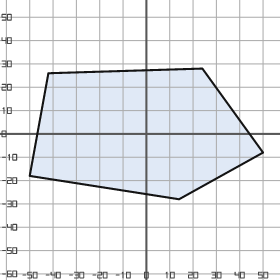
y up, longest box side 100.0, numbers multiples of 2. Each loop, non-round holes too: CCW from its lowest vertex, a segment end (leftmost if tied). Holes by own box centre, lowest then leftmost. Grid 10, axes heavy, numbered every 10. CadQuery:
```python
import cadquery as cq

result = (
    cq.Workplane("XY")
    .moveTo(14.0, -28.0)
    .lineTo(50.0, -8.0)
    .lineTo(24.0, 28.0)
    .lineTo(-42.0, 26.0)
    .lineTo(-50.0, -18.0)
    .close()
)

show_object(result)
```